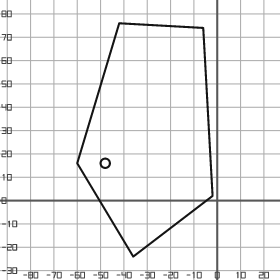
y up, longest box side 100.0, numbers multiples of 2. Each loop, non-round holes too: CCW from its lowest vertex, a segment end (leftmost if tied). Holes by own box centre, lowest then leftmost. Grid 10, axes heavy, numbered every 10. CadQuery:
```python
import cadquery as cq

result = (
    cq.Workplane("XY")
    .moveTo(-36.0, -24.0)
    .lineTo(-2.0, 2.0)
    .lineTo(-6.0, 74.0)
    .lineTo(-42.0, 76.0)
    .lineTo(-60.0, 16.0)
    .close()
    .moveTo(-48.0, 16.0)
    .circle(2.0)
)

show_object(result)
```